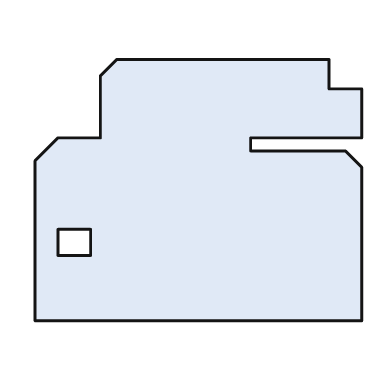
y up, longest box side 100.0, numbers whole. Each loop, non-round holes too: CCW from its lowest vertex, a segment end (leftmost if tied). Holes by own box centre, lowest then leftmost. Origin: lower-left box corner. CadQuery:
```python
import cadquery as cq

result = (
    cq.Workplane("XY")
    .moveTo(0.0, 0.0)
    .lineTo(100.0, 0.0)
    .lineTo(100.0, 47.0)
    .lineTo(95.0, 52.0)
    .lineTo(66.0, 52.0)
    .lineTo(66.0, 56.0)
    .lineTo(100.0, 56.0)
    .lineTo(100.0, 71.0)
    .lineTo(90.0, 71.0)
    .lineTo(90.0, 80.0)
    .lineTo(25.0, 80.0)
    .lineTo(20.0, 75.0)
    .lineTo(20.0, 56.0)
    .lineTo(7.0, 56.0)
    .lineTo(0.0, 49.0)
    .close()
    .moveTo(7.0, 20.0)
    .lineTo(17.0, 20.0)
    .lineTo(17.0, 28.0)
    .lineTo(7.0, 28.0)
    .close()
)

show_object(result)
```